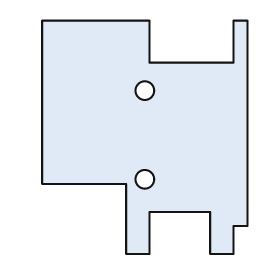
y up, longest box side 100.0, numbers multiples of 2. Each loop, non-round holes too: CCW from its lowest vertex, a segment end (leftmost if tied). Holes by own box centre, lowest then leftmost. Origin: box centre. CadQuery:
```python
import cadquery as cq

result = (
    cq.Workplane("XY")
    .moveTo(-8.0, -50.0)
    .lineTo(2.0, -50.0)
    .lineTo(2.0, -32.0)
    .lineTo(28.0, -32.0)
    .lineTo(28.0, -50.0)
    .lineTo(38.0, -50.0)
    .lineTo(38.0, -38.0)
    .lineTo(44.0, -38.0)
    .lineTo(44.0, 50.0)
    .lineTo(38.0, 50.0)
    .lineTo(38.0, 32.0)
    .lineTo(2.0, 32.0)
    .lineTo(2.0, 50.0)
    .lineTo(-44.0, 50.0)
    .lineTo(-44.0, -20.0)
    .lineTo(-8.0, -20.0)
    .close()
    .moveTo(0.0, -18.0)
    .circle(4.0)
    .moveTo(0.0, 20.0)
    .circle(4.0)
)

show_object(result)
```